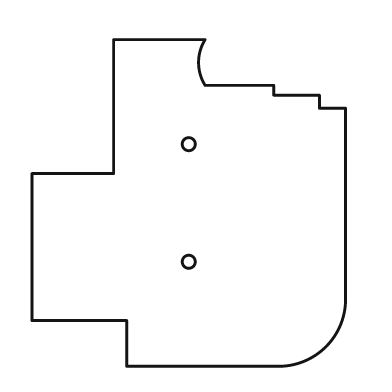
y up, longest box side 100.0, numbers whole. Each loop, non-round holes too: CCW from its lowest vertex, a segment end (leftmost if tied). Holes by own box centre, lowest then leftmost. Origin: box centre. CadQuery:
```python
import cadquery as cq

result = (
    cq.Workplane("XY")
    .moveTo(-19.0, -50.0)
    .lineTo(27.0, -50.0)
    .threePointArc((42.0, -44.0), (48.0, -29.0))
    .lineTo(48.0, 29.0)
    .lineTo(40.0, 29.0)
    .lineTo(40.0, 33.0)
    .lineTo(26.0, 33.0)
    .lineTo(26.0, 36.0)
    .lineTo(5.0, 36.0)
    .threePointArc((3.0, 43.0), (5.0, 50.0))
    .lineTo(-23.0, 50.0)
    .lineTo(-23.0, 9.0)
    .lineTo(-48.0, 9.0)
    .lineTo(-48.0, -36.0)
    .lineTo(-19.0, -36.0)
    .close()
    .moveTo(0.0, -18.0)
    .circle(2.0)
    .moveTo(0.0, 18.0)
    .circle(2.0)
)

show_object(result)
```